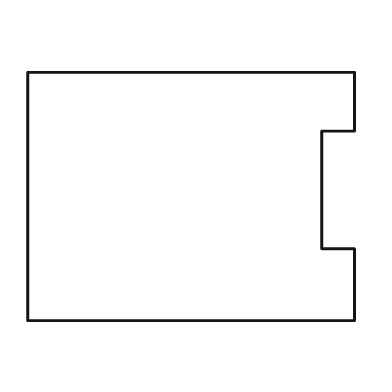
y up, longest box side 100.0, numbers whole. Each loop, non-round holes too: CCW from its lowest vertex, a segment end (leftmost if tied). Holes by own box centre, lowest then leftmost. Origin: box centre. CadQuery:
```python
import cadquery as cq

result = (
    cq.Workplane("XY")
    .moveTo(-50.0, -38.0)
    .lineTo(50.0, -38.0)
    .lineTo(50.0, -16.0)
    .lineTo(40.0, -16.0)
    .lineTo(40.0, 20.0)
    .lineTo(50.0, 20.0)
    .lineTo(50.0, 38.0)
    .lineTo(-50.0, 38.0)
    .close()
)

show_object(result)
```